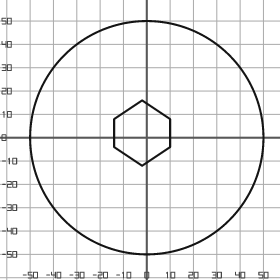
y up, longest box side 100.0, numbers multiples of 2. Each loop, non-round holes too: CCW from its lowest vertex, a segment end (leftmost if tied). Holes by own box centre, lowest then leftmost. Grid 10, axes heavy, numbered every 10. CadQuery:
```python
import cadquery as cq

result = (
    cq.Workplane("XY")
    .moveTo(0.0, 0.0)
    .circle(50.0)
    .moveTo(-2.0, -12.0)
    .lineTo(10.0, -4.0)
    .lineTo(10.0, 8.0)
    .lineTo(-2.0, 16.0)
    .lineTo(-14.0, 8.0)
    .lineTo(-14.0, -4.0)
    .close()
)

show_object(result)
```